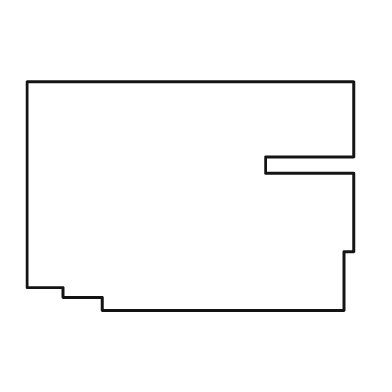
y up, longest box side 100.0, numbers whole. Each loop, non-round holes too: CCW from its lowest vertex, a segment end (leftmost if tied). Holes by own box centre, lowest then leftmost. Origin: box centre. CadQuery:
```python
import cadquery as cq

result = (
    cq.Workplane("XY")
    .moveTo(-27.0, -35.0)
    .lineTo(47.0, -35.0)
    .lineTo(47.0, -17.0)
    .lineTo(50.0, -17.0)
    .lineTo(50.0, 7.0)
    .lineTo(23.0, 7.0)
    .lineTo(23.0, 12.0)
    .lineTo(50.0, 12.0)
    .lineTo(50.0, 35.0)
    .lineTo(-50.0, 35.0)
    .lineTo(-50.0, -28.0)
    .lineTo(-39.0, -28.0)
    .lineTo(-39.0, -31.0)
    .lineTo(-27.0, -31.0)
    .close()
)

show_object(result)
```